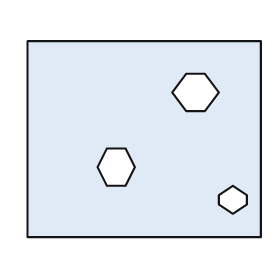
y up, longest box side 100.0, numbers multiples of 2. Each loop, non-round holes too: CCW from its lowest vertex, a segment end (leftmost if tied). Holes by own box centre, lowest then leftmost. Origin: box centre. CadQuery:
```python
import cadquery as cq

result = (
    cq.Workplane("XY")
    .moveTo(-50.0, -42.0)
    .lineTo(50.0, -42.0)
    .lineTo(50.0, 42.0)
    .lineTo(-50.0, 42.0)
    .close()
    .moveTo(38.0, -32.0)
    .lineTo(44.0, -28.0)
    .lineTo(44.0, -24.0)
    .lineTo(38.0, -20.0)
    .lineTo(32.0, -24.0)
    .lineTo(32.0, -28.0)
    .close()
    .moveTo(-16.0, -20.0)
    .lineTo(-8.0, -20.0)
    .lineTo(-4.0, -12.0)
    .lineTo(-8.0, -4.0)
    .lineTo(-16.0, -4.0)
    .lineTo(-20.0, -12.0)
    .close()
    .moveTo(18.0, 12.0)
    .lineTo(26.0, 12.0)
    .lineTo(32.0, 20.0)
    .lineTo(26.0, 28.0)
    .lineTo(18.0, 28.0)
    .lineTo(12.0, 20.0)
    .close()
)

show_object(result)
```